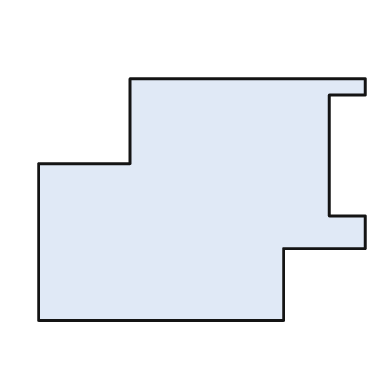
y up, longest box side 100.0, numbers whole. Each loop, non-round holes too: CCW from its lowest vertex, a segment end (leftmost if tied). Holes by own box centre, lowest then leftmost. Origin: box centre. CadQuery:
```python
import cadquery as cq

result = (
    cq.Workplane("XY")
    .moveTo(-50.0, -37.0)
    .lineTo(25.0, -37.0)
    .lineTo(25.0, -15.0)
    .lineTo(50.0, -15.0)
    .lineTo(50.0, -5.0)
    .lineTo(39.0, -5.0)
    .lineTo(39.0, 32.0)
    .lineTo(50.0, 32.0)
    .lineTo(50.0, 37.0)
    .lineTo(-22.0, 37.0)
    .lineTo(-22.0, 11.0)
    .lineTo(-50.0, 11.0)
    .close()
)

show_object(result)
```